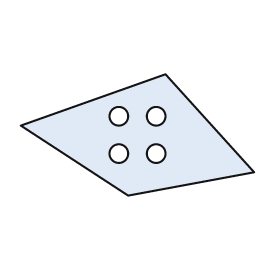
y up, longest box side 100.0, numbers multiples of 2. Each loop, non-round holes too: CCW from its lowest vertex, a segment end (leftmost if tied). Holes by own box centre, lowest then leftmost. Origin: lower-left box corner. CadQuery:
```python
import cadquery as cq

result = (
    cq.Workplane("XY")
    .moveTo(46.0, 0.0)
    .lineTo(100.0, 10.0)
    .lineTo(62.0, 52.0)
    .lineTo(0.0, 30.0)
    .close()
    .moveTo(42.0, 18.0)
    .circle(4.0)
    .moveTo(58.0, 18.0)
    .circle(4.0)
    .moveTo(42.0, 34.0)
    .circle(4.0)
    .moveTo(58.0, 34.0)
    .circle(4.0)
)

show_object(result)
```